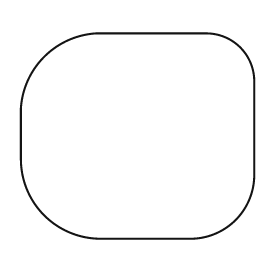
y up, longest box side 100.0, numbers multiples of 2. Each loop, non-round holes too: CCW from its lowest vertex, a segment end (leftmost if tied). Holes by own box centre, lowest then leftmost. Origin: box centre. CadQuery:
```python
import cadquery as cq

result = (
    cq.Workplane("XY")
    .moveTo(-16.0, -44.0)
    .lineTo(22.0, -44.0)
    .threePointArc((42.0, -36.0), (50.0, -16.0))
    .lineTo(50.0, 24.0)
    .threePointArc((44.0, 38.0), (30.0, 44.0))
    .lineTo(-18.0, 44.0)
    .threePointArc((-40.0, 34.0), (-50.0, 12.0))
    .lineTo(-50.0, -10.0)
    .threePointArc((-40.0, -34.0), (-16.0, -44.0))
    .close()
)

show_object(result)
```